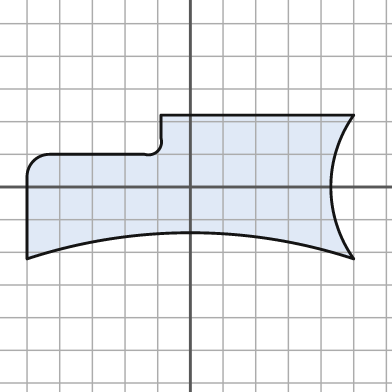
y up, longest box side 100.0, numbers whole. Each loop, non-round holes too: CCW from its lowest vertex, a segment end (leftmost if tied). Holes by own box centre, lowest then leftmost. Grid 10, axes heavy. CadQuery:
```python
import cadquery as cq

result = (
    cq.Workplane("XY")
    .moveTo(-50.0, -22.0)
    .threePointArc((0.0, -14.0), (50.0, -22.0))
    .threePointArc((43.0, 0.0), (50.0, 22.0))
    .lineTo(-9.0, 22.0)
    .lineTo(-9.0, 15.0)
    .threePointArc((-10.0, 11.0), (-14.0, 10.0))
    .lineTo(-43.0, 10.0)
    .threePointArc((-48.0, 8.0), (-50.0, 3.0))
    .close()
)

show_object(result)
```